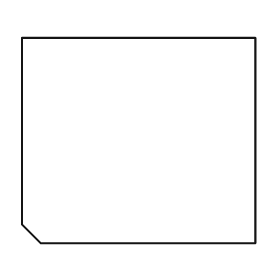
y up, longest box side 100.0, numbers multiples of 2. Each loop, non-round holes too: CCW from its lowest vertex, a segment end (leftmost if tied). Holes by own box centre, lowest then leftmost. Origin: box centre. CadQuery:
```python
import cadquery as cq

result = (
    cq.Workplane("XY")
    .moveTo(-42.0, -44.0)
    .lineTo(50.0, -44.0)
    .lineTo(50.0, 44.0)
    .lineTo(-50.0, 44.0)
    .lineTo(-50.0, -36.0)
    .close()
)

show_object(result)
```